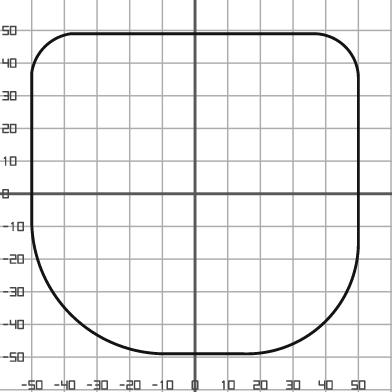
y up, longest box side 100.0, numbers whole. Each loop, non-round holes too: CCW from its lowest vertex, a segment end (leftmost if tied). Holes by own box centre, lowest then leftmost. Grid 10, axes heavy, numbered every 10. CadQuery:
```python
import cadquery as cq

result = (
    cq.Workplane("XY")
    .moveTo(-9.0, -49.0)
    .lineTo(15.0, -49.0)
    .threePointArc((40.0, -39.0), (50.0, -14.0))
    .lineTo(50.0, 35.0)
    .threePointArc((46.0, 45.0), (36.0, 49.0))
    .lineTo(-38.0, 49.0)
    .threePointArc((-46.0, 45.0), (-50.0, 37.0))
    .lineTo(-50.0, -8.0)
    .threePointArc((-38.0, -37.0), (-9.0, -49.0))
    .close()
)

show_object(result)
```